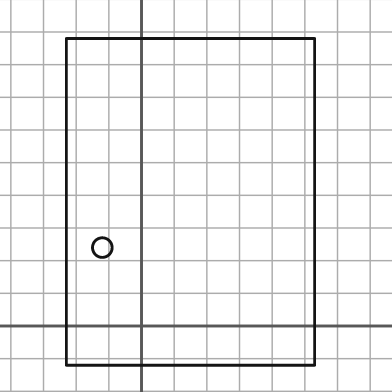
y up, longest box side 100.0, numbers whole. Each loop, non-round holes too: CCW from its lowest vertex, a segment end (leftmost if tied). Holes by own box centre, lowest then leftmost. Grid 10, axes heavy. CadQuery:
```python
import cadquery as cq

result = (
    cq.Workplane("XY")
    .moveTo(-23.0, -12.0)
    .lineTo(53.0, -12.0)
    .lineTo(53.0, 88.0)
    .lineTo(-23.0, 88.0)
    .close()
    .moveTo(-12.0, 24.0)
    .circle(3.0)
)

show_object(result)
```